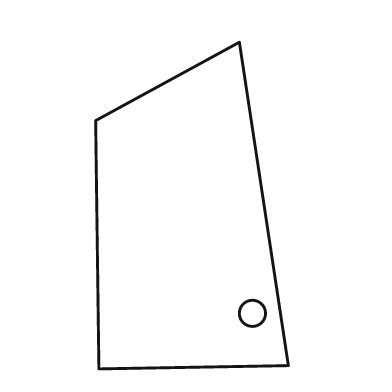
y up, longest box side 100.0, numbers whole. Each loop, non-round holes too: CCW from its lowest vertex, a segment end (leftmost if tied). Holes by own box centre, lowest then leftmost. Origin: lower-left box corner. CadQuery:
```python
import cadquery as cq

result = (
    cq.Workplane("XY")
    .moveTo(1.0, 0.0)
    .lineTo(59.0, 1.0)
    .lineTo(44.0, 100.0)
    .lineTo(0.0, 76.0)
    .close()
    .moveTo(48.0, 17.0)
    .circle(4.0)
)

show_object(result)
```